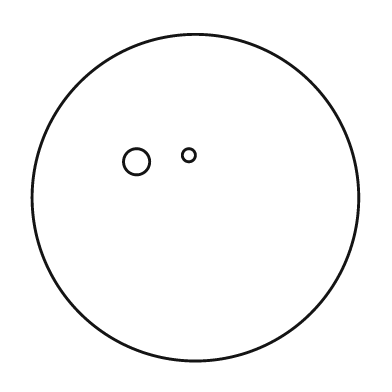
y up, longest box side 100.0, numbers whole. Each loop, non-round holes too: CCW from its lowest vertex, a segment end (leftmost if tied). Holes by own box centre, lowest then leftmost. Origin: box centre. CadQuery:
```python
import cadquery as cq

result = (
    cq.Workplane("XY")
    .moveTo(0.0, 0.0)
    .circle(50.0)
    .moveTo(-18.0, 11.0)
    .circle(4.0)
    .moveTo(-2.0, 13.0)
    .circle(2.0)
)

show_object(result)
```